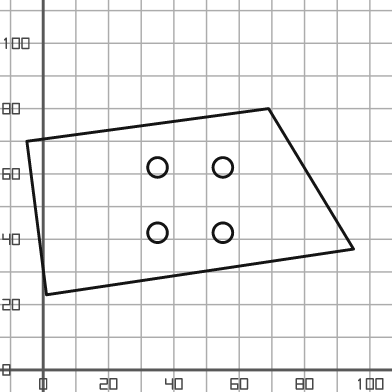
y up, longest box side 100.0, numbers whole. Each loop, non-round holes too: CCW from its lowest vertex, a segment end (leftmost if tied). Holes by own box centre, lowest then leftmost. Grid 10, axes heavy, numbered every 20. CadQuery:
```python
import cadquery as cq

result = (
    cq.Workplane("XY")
    .moveTo(1.0, 23.0)
    .lineTo(95.0, 37.0)
    .lineTo(69.0, 80.0)
    .lineTo(-5.0, 70.0)
    .close()
    .moveTo(35.0, 42.0)
    .circle(3.0)
    .moveTo(55.0, 42.0)
    .circle(3.0)
    .moveTo(35.0, 62.0)
    .circle(3.0)
    .moveTo(55.0, 62.0)
    .circle(3.0)
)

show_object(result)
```